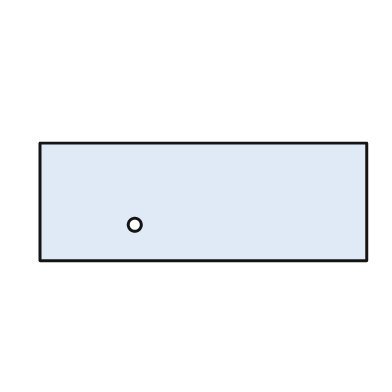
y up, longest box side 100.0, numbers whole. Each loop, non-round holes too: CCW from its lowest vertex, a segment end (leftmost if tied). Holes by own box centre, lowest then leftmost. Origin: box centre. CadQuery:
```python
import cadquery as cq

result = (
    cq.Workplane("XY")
    .moveTo(-50.0, -18.0)
    .lineTo(50.0, -18.0)
    .lineTo(50.0, 18.0)
    .lineTo(-50.0, 18.0)
    .close()
    .moveTo(-21.0, -7.0)
    .circle(2.0)
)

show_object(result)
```